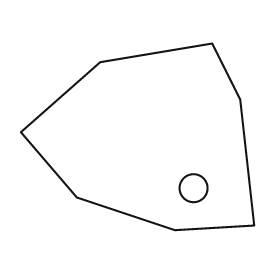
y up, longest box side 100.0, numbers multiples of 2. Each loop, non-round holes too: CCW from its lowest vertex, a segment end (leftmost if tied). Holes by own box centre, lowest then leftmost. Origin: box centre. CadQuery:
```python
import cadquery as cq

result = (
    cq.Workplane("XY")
    .moveTo(16.0, -40.0)
    .lineTo(50.0, -38.0)
    .lineTo(44.0, 16.0)
    .lineTo(32.0, 40.0)
    .lineTo(-16.0, 32.0)
    .lineTo(-50.0, 2.0)
    .lineTo(-26.0, -26.0)
    .close()
    .moveTo(24.0, -22.0)
    .circle(6.0)
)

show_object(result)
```